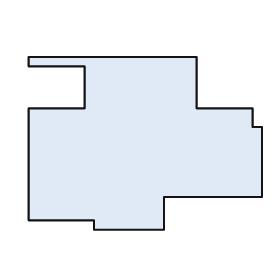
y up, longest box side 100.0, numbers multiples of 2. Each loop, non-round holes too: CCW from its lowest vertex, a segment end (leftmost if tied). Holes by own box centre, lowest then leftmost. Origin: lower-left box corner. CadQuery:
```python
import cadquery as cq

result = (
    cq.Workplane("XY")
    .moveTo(28.0, 0.0)
    .lineTo(58.0, 0.0)
    .lineTo(58.0, 14.0)
    .lineTo(100.0, 14.0)
    .lineTo(100.0, 44.0)
    .lineTo(96.0, 44.0)
    .lineTo(96.0, 52.0)
    .lineTo(72.0, 52.0)
    .lineTo(72.0, 74.0)
    .lineTo(0.0, 74.0)
    .lineTo(0.0, 70.0)
    .lineTo(24.0, 70.0)
    .lineTo(24.0, 52.0)
    .lineTo(0.0, 52.0)
    .lineTo(0.0, 4.0)
    .lineTo(28.0, 4.0)
    .close()
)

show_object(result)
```